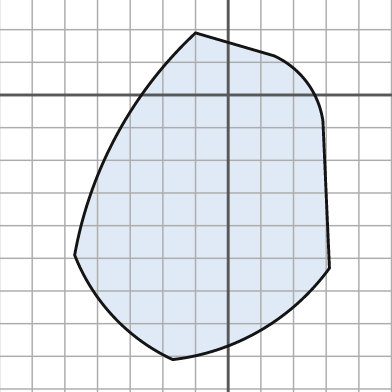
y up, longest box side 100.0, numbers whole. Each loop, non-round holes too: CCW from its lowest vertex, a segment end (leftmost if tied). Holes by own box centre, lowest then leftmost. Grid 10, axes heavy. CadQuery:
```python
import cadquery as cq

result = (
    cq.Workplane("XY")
    .moveTo(-17.0, -81.0)
    .threePointArc((10.0, -72.0), (31.0, -53.0))
    .lineTo(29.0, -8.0)
    .threePointArc((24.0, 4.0), (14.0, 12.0))
    .lineTo(-10.0, 19.0)
    .threePointArc((-34.0, -12.0), (-47.0, -49.0))
    .threePointArc((-35.0, -68.0), (-17.0, -81.0))
    .close()
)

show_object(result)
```